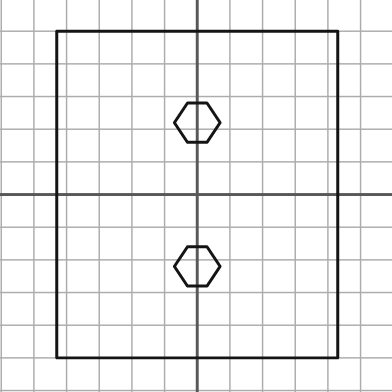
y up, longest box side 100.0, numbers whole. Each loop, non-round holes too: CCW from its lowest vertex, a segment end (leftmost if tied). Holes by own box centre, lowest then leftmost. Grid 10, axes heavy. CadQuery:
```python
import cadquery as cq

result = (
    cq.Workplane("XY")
    .moveTo(-43.0, -50.0)
    .lineTo(43.0, -50.0)
    .lineTo(43.0, 50.0)
    .lineTo(-43.0, 50.0)
    .close()
    .moveTo(-3.0, -28.0)
    .lineTo(3.0, -28.0)
    .lineTo(7.0, -22.0)
    .lineTo(3.0, -16.0)
    .lineTo(-3.0, -16.0)
    .lineTo(-7.0, -22.0)
    .close()
    .moveTo(-3.0, 16.0)
    .lineTo(3.0, 16.0)
    .lineTo(7.0, 22.0)
    .lineTo(3.0, 28.0)
    .lineTo(-3.0, 28.0)
    .lineTo(-7.0, 22.0)
    .close()
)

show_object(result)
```